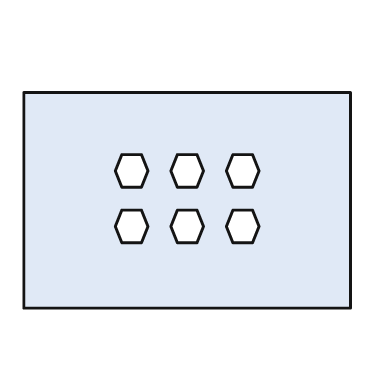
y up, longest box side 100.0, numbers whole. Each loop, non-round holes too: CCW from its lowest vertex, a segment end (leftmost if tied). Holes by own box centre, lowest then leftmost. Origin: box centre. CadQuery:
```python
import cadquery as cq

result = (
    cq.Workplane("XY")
    .moveTo(-50.0, -33.0)
    .lineTo(50.0, -33.0)
    .lineTo(50.0, 33.0)
    .lineTo(-50.0, 33.0)
    .close()
    .moveTo(-20.0, -13.0)
    .lineTo(-14.0, -13.0)
    .lineTo(-12.0, -8.0)
    .lineTo(-14.0, -3.0)
    .lineTo(-20.0, -3.0)
    .lineTo(-22.0, -8.0)
    .close()
    .moveTo(-3.0, -13.0)
    .lineTo(3.0, -13.0)
    .lineTo(5.0, -8.0)
    .lineTo(3.0, -3.0)
    .lineTo(-3.0, -3.0)
    .lineTo(-5.0, -8.0)
    .close()
    .moveTo(14.0, -13.0)
    .lineTo(20.0, -13.0)
    .lineTo(22.0, -8.0)
    .lineTo(20.0, -3.0)
    .lineTo(14.0, -3.0)
    .lineTo(12.0, -8.0)
    .close()
    .moveTo(-20.0, 4.0)
    .lineTo(-14.0, 4.0)
    .lineTo(-12.0, 9.0)
    .lineTo(-14.0, 14.0)
    .lineTo(-20.0, 14.0)
    .lineTo(-22.0, 9.0)
    .close()
    .moveTo(-3.0, 4.0)
    .lineTo(3.0, 4.0)
    .lineTo(5.0, 9.0)
    .lineTo(3.0, 14.0)
    .lineTo(-3.0, 14.0)
    .lineTo(-5.0, 9.0)
    .close()
    .moveTo(14.0, 4.0)
    .lineTo(20.0, 4.0)
    .lineTo(22.0, 9.0)
    .lineTo(20.0, 14.0)
    .lineTo(14.0, 14.0)
    .lineTo(12.0, 9.0)
    .close()
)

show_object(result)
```